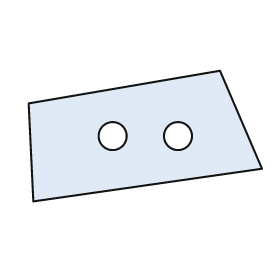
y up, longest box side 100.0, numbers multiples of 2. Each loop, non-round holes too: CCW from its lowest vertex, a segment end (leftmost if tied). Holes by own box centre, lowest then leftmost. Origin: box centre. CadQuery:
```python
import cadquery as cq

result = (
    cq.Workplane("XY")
    .moveTo(-48.0, -28.0)
    .lineTo(50.0, -14.0)
    .lineTo(32.0, 28.0)
    .lineTo(-50.0, 14.0)
    .close()
    .moveTo(-14.0, 0.0)
    .circle(6.0)
    .moveTo(14.0, 0.0)
    .circle(6.0)
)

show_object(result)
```